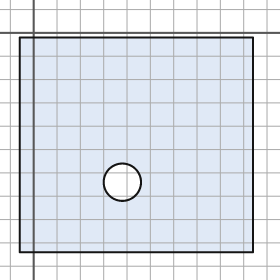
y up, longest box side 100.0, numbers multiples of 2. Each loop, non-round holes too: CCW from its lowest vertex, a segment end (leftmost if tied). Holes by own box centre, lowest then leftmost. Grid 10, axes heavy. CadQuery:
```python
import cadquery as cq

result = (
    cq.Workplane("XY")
    .moveTo(-6.0, -94.0)
    .lineTo(94.0, -94.0)
    .lineTo(94.0, -2.0)
    .lineTo(-6.0, -2.0)
    .close()
    .moveTo(38.0, -64.0)
    .circle(8.0)
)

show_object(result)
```